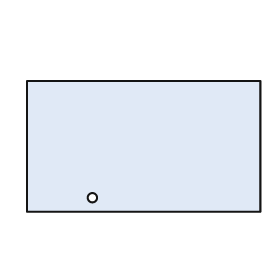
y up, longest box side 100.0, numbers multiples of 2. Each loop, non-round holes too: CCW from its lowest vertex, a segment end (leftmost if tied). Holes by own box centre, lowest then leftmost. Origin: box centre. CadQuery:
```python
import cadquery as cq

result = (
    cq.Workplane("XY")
    .moveTo(-50.0, -28.0)
    .lineTo(50.0, -28.0)
    .lineTo(50.0, 28.0)
    .lineTo(-50.0, 28.0)
    .close()
    .moveTo(-22.0, -22.0)
    .circle(2.0)
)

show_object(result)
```